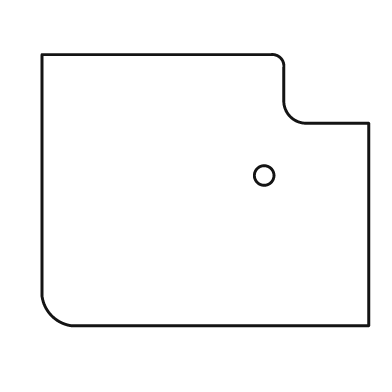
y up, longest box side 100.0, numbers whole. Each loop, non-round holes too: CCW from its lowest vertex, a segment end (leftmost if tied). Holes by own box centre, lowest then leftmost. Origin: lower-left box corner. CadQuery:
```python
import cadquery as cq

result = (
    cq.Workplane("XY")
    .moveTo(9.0, 0.0)
    .lineTo(100.0, 0.0)
    .lineTo(100.0, 62.0)
    .lineTo(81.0, 62.0)
    .threePointArc((76.0, 64.0), (74.0, 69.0))
    .lineTo(74.0, 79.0)
    .threePointArc((73.0, 82.0), (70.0, 83.0))
    .lineTo(0.0, 83.0)
    .lineTo(0.0, 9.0)
    .threePointArc((3.0, 3.0), (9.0, 0.0))
    .close()
    .moveTo(68.0, 46.0)
    .circle(3.0)
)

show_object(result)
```